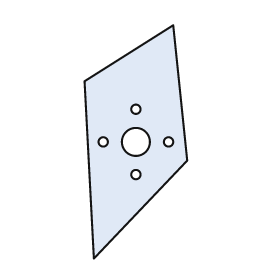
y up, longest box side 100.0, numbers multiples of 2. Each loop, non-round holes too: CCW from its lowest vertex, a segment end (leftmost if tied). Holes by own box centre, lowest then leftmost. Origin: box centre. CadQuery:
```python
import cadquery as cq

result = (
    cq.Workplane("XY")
    .moveTo(-18.0, -50.0)
    .lineTo(22.0, -8.0)
    .lineTo(16.0, 50.0)
    .lineTo(-22.0, 26.0)
    .close()
    .moveTo(0.0, -14.0)
    .circle(2.0)
    .moveTo(-14.0, 0.0)
    .circle(2.0)
    .moveTo(0.0, 0.0)
    .circle(6.0)
    .moveTo(14.0, 0.0)
    .circle(2.0)
    .moveTo(0.0, 14.0)
    .circle(2.0)
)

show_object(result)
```